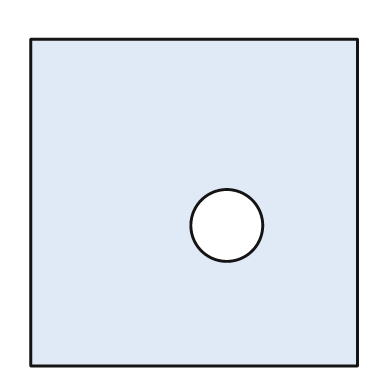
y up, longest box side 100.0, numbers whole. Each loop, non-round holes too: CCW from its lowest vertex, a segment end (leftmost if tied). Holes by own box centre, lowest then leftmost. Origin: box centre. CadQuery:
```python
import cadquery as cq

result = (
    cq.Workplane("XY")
    .moveTo(-50.0, -50.0)
    .lineTo(50.0, -50.0)
    .lineTo(50.0, 50.0)
    .lineTo(-50.0, 50.0)
    .close()
    .moveTo(10.0, -7.0)
    .circle(11.0)
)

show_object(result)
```